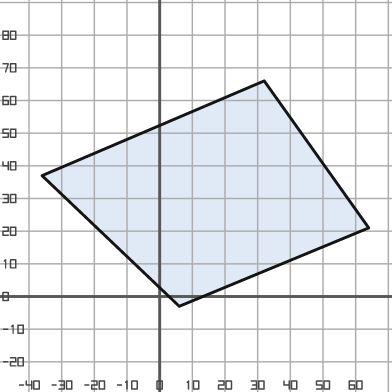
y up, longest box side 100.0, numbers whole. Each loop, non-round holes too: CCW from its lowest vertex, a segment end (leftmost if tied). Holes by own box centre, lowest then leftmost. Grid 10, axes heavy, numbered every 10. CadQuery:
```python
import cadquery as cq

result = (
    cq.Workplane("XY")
    .moveTo(6.0, -3.0)
    .lineTo(64.0, 21.0)
    .lineTo(32.0, 66.0)
    .lineTo(-36.0, 37.0)
    .close()
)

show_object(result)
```